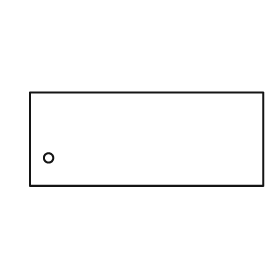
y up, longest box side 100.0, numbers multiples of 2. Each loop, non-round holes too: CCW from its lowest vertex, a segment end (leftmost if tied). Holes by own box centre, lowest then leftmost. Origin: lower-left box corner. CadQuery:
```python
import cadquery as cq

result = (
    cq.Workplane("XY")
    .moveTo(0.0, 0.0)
    .lineTo(100.0, 0.0)
    .lineTo(100.0, 40.0)
    .lineTo(0.0, 40.0)
    .close()
    .moveTo(8.0, 12.0)
    .circle(2.0)
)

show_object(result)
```